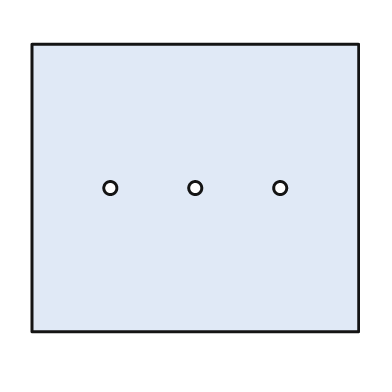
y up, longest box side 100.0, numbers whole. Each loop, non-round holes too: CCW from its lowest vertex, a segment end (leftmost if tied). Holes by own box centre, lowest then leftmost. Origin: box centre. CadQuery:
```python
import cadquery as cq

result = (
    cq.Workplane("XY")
    .moveTo(-50.0, -44.0)
    .lineTo(50.0, -44.0)
    .lineTo(50.0, 44.0)
    .lineTo(-50.0, 44.0)
    .close()
    .moveTo(-26.0, 0.0)
    .circle(2.0)
    .moveTo(0.0, 0.0)
    .circle(2.0)
    .moveTo(26.0, 0.0)
    .circle(2.0)
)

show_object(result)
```